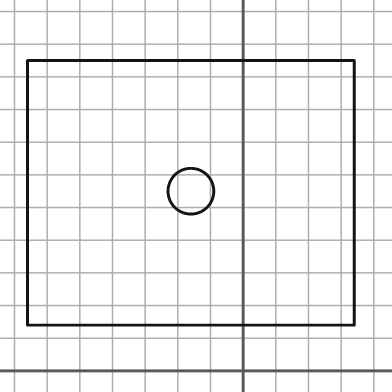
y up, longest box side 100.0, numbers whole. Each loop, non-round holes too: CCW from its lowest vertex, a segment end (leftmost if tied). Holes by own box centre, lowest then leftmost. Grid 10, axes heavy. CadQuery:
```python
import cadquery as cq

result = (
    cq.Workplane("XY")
    .moveTo(-66.0, 14.0)
    .lineTo(34.0, 14.0)
    .lineTo(34.0, 95.0)
    .lineTo(-66.0, 95.0)
    .close()
    .moveTo(-16.0, 55.0)
    .circle(7.0)
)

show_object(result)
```